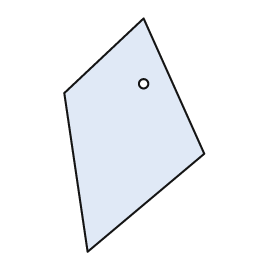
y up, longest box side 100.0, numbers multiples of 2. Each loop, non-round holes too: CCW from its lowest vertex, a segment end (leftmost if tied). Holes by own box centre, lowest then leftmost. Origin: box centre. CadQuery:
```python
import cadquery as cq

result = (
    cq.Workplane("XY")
    .moveTo(-20.0, -50.0)
    .lineTo(30.0, -8.0)
    .lineTo(4.0, 50.0)
    .lineTo(-30.0, 18.0)
    .close()
    .moveTo(4.0, 22.0)
    .circle(2.0)
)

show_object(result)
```